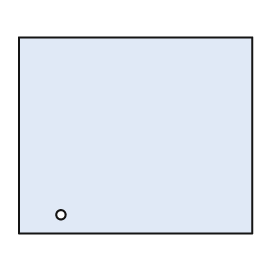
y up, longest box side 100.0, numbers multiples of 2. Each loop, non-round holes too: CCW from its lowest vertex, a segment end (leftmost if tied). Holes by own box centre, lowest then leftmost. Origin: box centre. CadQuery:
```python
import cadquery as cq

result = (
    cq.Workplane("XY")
    .moveTo(-50.0, -42.0)
    .lineTo(50.0, -42.0)
    .lineTo(50.0, 42.0)
    .lineTo(-50.0, 42.0)
    .close()
    .moveTo(-32.0, -34.0)
    .circle(2.0)
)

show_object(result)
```